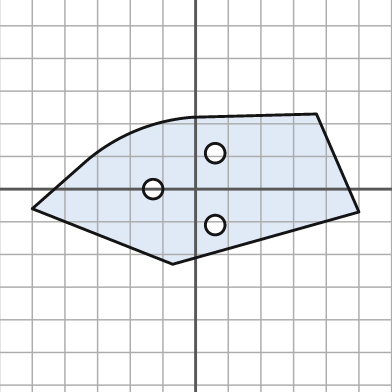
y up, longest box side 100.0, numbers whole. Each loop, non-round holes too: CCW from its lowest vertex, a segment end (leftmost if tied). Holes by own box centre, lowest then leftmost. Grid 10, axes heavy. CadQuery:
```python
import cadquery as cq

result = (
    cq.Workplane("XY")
    .moveTo(-7.0, -23.0)
    .lineTo(50.0, -7.0)
    .lineTo(37.0, 23.0)
    .lineTo(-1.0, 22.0)
    .threePointArc((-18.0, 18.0), (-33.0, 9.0))
    .lineTo(-50.0, -6.0)
    .close()
    .moveTo(6.0, -11.0)
    .circle(3.0)
    .moveTo(-13.0, 0.0)
    .circle(3.0)
    .moveTo(6.0, 11.0)
    .circle(3.0)
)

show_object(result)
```